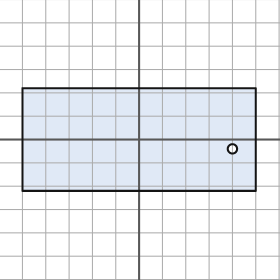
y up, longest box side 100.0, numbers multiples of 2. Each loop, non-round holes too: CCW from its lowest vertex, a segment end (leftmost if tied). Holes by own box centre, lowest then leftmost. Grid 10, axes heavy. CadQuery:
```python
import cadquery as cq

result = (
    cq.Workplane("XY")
    .moveTo(-50.0, -22.0)
    .lineTo(50.0, -22.0)
    .lineTo(50.0, 22.0)
    .lineTo(-50.0, 22.0)
    .close()
    .moveTo(40.0, -4.0)
    .circle(2.0)
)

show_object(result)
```